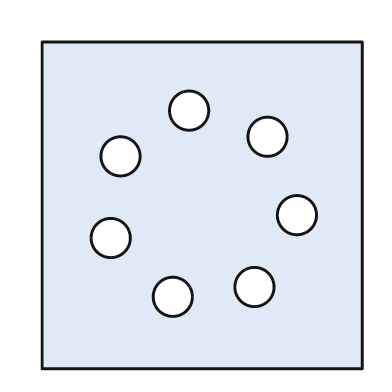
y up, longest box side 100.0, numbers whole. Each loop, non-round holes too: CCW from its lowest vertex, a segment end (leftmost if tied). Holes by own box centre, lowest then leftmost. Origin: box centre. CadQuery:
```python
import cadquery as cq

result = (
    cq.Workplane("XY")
    .moveTo(-49.0, -50.0)
    .lineTo(49.0, -50.0)
    .lineTo(49.0, 50.0)
    .lineTo(-49.0, 50.0)
    .close()
    .moveTo(-9.0, -28.0)
    .circle(6.0)
    .moveTo(16.0, -25.0)
    .circle(6.0)
    .moveTo(-28.0, -10.0)
    .circle(6.0)
    .moveTo(29.0, -3.0)
    .circle(6.0)
    .moveTo(-25.0, 15.0)
    .circle(6.0)
    .moveTo(20.0, 21.0)
    .circle(6.0)
    .moveTo(-4.0, 29.0)
    .circle(6.0)
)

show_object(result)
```